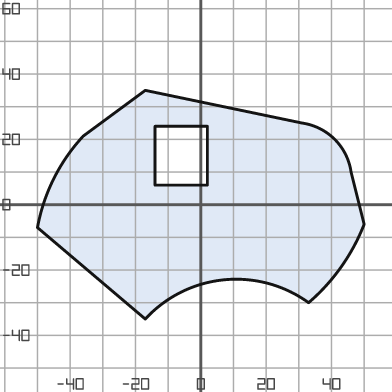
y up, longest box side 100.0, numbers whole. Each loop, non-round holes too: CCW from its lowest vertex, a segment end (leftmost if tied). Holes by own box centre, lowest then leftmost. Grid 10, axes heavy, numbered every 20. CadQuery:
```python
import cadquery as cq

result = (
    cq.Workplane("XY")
    .moveTo(-17.0, -35.0)
    .threePointArc((7.0, -23.0), (33.0, -30.0))
    .threePointArc((43.0, -19.0), (50.0, -6.0))
    .lineTo(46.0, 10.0)
    .threePointArc((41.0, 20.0), (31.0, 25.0))
    .lineTo(-17.0, 35.0)
    .lineTo(-36.0, 21.0)
    .threePointArc((-45.0, 8.0), (-50.0, -7.0))
    .close()
    .moveTo(-14.0, 6.0)
    .lineTo(2.0, 6.0)
    .lineTo(2.0, 24.0)
    .lineTo(-14.0, 24.0)
    .close()
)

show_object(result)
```